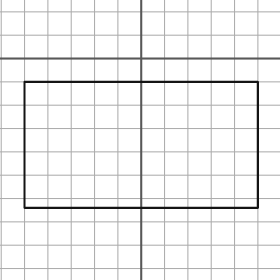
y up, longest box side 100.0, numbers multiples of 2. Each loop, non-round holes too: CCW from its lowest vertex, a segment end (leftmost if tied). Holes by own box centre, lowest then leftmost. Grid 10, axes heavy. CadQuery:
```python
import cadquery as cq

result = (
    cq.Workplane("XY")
    .moveTo(-50.0, -64.0)
    .lineTo(50.0, -64.0)
    .lineTo(50.0, -10.0)
    .lineTo(-50.0, -10.0)
    .close()
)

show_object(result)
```